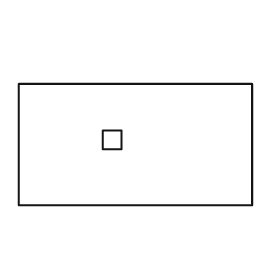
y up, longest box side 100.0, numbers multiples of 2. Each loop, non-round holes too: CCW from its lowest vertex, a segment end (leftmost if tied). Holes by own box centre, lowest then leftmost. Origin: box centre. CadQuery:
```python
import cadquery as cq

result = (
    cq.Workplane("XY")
    .moveTo(-50.0, -26.0)
    .lineTo(50.0, -26.0)
    .lineTo(50.0, 26.0)
    .lineTo(-50.0, 26.0)
    .close()
    .moveTo(-14.0, -2.0)
    .lineTo(-6.0, -2.0)
    .lineTo(-6.0, 6.0)
    .lineTo(-14.0, 6.0)
    .close()
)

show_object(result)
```